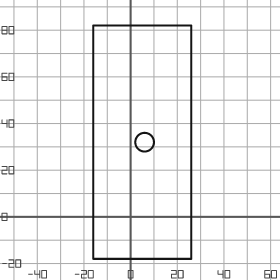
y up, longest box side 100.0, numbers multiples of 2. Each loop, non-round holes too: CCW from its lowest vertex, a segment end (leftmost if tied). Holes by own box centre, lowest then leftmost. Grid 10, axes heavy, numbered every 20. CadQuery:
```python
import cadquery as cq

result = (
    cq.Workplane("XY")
    .moveTo(-16.0, -18.0)
    .lineTo(26.0, -18.0)
    .lineTo(26.0, 82.0)
    .lineTo(-16.0, 82.0)
    .close()
    .moveTo(6.0, 32.0)
    .circle(4.0)
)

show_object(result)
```